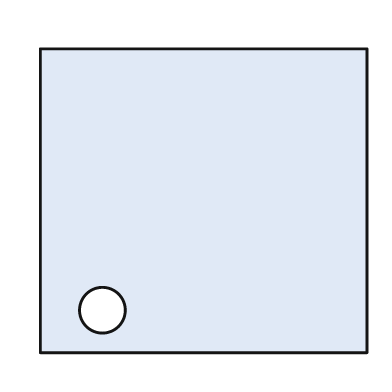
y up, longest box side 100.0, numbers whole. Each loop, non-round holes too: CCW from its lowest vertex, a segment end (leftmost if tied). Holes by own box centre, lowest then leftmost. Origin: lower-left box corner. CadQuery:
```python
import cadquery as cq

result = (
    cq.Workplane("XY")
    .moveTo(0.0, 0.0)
    .lineTo(100.0, 0.0)
    .lineTo(100.0, 93.0)
    .lineTo(0.0, 93.0)
    .close()
    .moveTo(19.0, 13.0)
    .circle(7.0)
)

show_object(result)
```